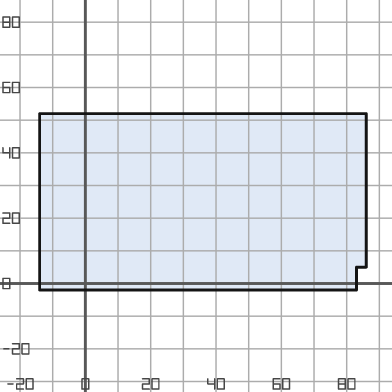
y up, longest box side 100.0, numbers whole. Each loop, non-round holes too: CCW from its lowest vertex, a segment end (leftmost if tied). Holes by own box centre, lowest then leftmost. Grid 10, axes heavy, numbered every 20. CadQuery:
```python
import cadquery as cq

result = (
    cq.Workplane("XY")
    .moveTo(-14.0, -2.0)
    .lineTo(83.0, -2.0)
    .lineTo(83.0, 5.0)
    .lineTo(86.0, 5.0)
    .lineTo(86.0, 52.0)
    .lineTo(-14.0, 52.0)
    .close()
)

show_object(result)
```